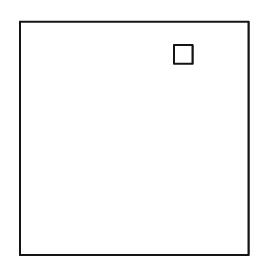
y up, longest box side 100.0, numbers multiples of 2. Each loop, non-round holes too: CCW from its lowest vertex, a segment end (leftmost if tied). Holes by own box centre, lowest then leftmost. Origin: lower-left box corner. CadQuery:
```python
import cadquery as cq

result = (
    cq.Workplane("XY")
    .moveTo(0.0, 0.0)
    .lineTo(98.0, 0.0)
    .lineTo(98.0, 100.0)
    .lineTo(0.0, 100.0)
    .close()
    .moveTo(66.0, 82.0)
    .lineTo(74.0, 82.0)
    .lineTo(74.0, 90.0)
    .lineTo(66.0, 90.0)
    .close()
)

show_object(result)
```